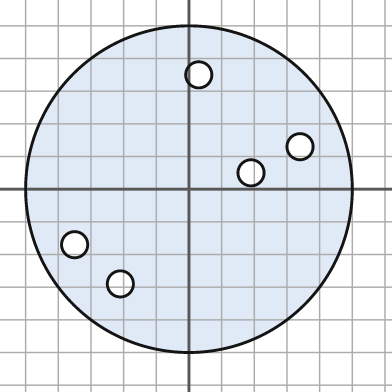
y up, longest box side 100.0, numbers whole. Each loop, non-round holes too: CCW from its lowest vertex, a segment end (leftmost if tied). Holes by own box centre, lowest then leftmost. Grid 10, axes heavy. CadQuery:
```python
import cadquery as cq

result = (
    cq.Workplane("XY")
    .moveTo(0.0, 0.0)
    .circle(50.0)
    .moveTo(-21.0, -29.0)
    .circle(4.0)
    .moveTo(-35.0, -17.0)
    .circle(4.0)
    .moveTo(19.0, 5.0)
    .circle(4.0)
    .moveTo(34.0, 13.0)
    .circle(4.0)
    .moveTo(3.0, 35.0)
    .circle(4.0)
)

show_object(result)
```